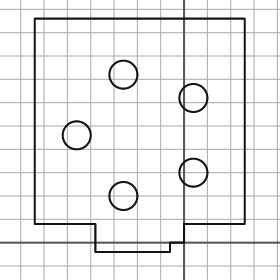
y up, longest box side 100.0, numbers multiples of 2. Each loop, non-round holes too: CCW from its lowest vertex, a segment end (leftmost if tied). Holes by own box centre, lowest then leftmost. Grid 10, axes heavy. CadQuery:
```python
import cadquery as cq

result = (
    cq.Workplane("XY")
    .moveTo(-38.0, -4.0)
    .lineTo(-6.0, -4.0)
    .lineTo(-6.0, 0.0)
    .lineTo(0.0, 0.0)
    .lineTo(0.0, 8.0)
    .lineTo(26.0, 8.0)
    .lineTo(26.0, 96.0)
    .lineTo(-64.0, 96.0)
    .lineTo(-64.0, 8.0)
    .lineTo(-38.0, 8.0)
    .close()
    .moveTo(-26.0, 20.0)
    .circle(6.0)
    .moveTo(4.0, 30.0)
    .circle(6.0)
    .moveTo(-46.0, 46.0)
    .circle(6.0)
    .moveTo(4.0, 62.0)
    .circle(6.0)
    .moveTo(-26.0, 72.0)
    .circle(6.0)
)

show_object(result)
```